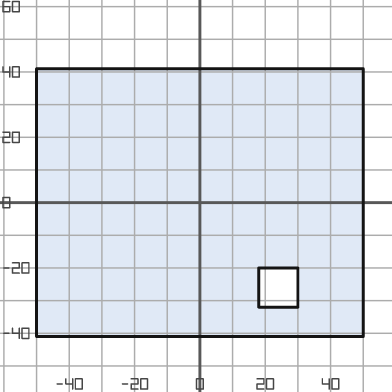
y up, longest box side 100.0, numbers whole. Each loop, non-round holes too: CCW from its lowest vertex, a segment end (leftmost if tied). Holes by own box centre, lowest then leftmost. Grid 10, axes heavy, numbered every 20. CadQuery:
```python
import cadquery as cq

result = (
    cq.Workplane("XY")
    .moveTo(-50.0, -41.0)
    .lineTo(50.0, -41.0)
    .lineTo(50.0, 41.0)
    .lineTo(-50.0, 41.0)
    .close()
    .moveTo(18.0, -32.0)
    .lineTo(30.0, -32.0)
    .lineTo(30.0, -20.0)
    .lineTo(18.0, -20.0)
    .close()
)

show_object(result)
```